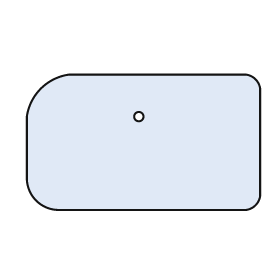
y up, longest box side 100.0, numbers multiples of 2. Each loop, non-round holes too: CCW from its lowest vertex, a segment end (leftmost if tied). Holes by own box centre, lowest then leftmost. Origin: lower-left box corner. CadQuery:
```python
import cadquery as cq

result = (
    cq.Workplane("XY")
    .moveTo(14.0, 0.0)
    .lineTo(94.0, 0.0)
    .threePointArc((98.0, 2.0), (100.0, 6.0))
    .lineTo(100.0, 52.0)
    .threePointArc((98.0, 56.0), (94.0, 58.0))
    .lineTo(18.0, 58.0)
    .threePointArc((6.0, 52.0), (0.0, 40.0))
    .lineTo(0.0, 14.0)
    .threePointArc((4.0, 4.0), (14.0, 0.0))
    .close()
    .moveTo(48.0, 40.0)
    .circle(2.0)
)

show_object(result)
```